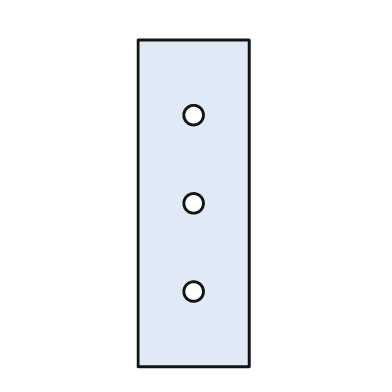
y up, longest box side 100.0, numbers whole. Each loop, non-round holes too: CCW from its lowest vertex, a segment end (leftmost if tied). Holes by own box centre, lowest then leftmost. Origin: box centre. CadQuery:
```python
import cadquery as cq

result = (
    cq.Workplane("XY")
    .moveTo(-17.0, -50.0)
    .lineTo(17.0, -50.0)
    .lineTo(17.0, 50.0)
    .lineTo(-17.0, 50.0)
    .close()
    .moveTo(0.0, -27.0)
    .circle(3.0)
    .moveTo(0.0, 0.0)
    .circle(3.0)
    .moveTo(0.0, 27.0)
    .circle(3.0)
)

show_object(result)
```